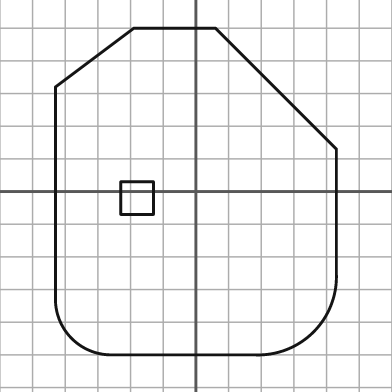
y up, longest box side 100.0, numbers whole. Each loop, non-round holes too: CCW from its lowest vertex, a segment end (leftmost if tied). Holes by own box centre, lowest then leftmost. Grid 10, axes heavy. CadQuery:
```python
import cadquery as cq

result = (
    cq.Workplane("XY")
    .moveTo(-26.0, -50.0)
    .lineTo(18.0, -50.0)
    .threePointArc((36.0, -43.0), (43.0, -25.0))
    .lineTo(43.0, 13.0)
    .lineTo(6.0, 50.0)
    .lineTo(-19.0, 50.0)
    .lineTo(-43.0, 32.0)
    .lineTo(-43.0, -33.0)
    .threePointArc((-38.0, -45.0), (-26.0, -50.0))
    .close()
    .moveTo(-23.0, -7.0)
    .lineTo(-13.0, -7.0)
    .lineTo(-13.0, 3.0)
    .lineTo(-23.0, 3.0)
    .close()
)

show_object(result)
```